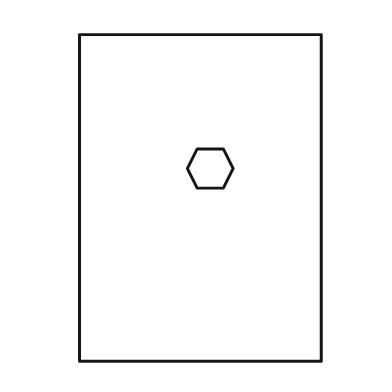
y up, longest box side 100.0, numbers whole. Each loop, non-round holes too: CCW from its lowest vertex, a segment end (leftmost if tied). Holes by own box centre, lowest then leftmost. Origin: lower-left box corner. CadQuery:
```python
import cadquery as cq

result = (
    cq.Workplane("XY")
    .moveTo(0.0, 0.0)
    .lineTo(74.0, 0.0)
    .lineTo(74.0, 100.0)
    .lineTo(0.0, 100.0)
    .close()
    .moveTo(36.0, 53.0)
    .lineTo(44.0, 53.0)
    .lineTo(47.0, 59.0)
    .lineTo(44.0, 65.0)
    .lineTo(36.0, 65.0)
    .lineTo(33.0, 59.0)
    .close()
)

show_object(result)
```